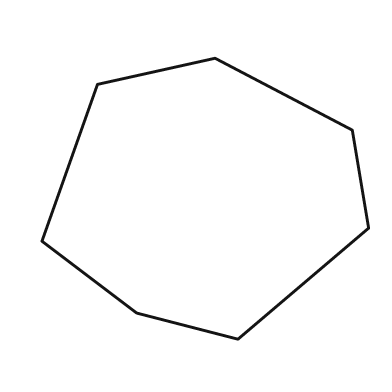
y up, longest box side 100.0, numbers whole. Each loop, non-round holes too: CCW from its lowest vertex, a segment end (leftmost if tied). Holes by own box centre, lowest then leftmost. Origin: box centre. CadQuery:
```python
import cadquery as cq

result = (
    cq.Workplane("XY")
    .moveTo(10.0, -43.0)
    .lineTo(50.0, -9.0)
    .lineTo(45.0, 21.0)
    .lineTo(3.0, 43.0)
    .lineTo(-33.0, 35.0)
    .lineTo(-50.0, -13.0)
    .lineTo(-21.0, -35.0)
    .close()
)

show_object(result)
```